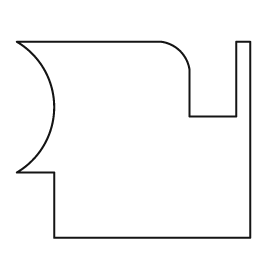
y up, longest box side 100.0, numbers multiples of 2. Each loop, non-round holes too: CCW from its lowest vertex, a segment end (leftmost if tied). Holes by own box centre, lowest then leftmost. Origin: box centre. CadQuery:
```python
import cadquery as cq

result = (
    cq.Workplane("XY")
    .moveTo(-34.0, -42.0)
    .lineTo(50.0, -42.0)
    .lineTo(50.0, 42.0)
    .lineTo(44.0, 42.0)
    .lineTo(44.0, 10.0)
    .lineTo(24.0, 10.0)
    .lineTo(24.0, 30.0)
    .threePointArc((20.0, 38.0), (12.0, 42.0))
    .lineTo(-50.0, 42.0)
    .threePointArc((-34.0, 14.0), (-50.0, -14.0))
    .lineTo(-34.0, -14.0)
    .close()
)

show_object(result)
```